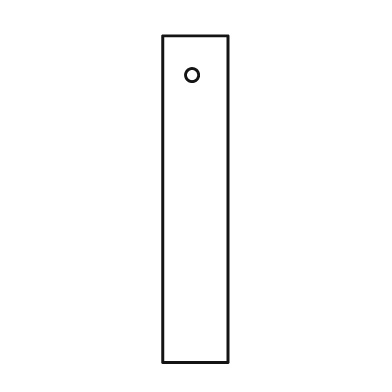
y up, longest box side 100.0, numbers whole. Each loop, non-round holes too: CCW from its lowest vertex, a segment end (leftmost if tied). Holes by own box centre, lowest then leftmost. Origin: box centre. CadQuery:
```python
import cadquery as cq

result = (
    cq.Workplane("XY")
    .moveTo(-10.0, -50.0)
    .lineTo(10.0, -50.0)
    .lineTo(10.0, 50.0)
    .lineTo(-10.0, 50.0)
    .close()
    .moveTo(-1.0, 38.0)
    .circle(2.0)
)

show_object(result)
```